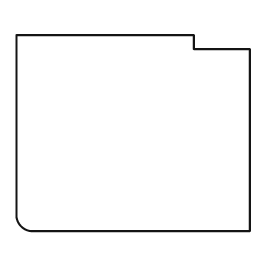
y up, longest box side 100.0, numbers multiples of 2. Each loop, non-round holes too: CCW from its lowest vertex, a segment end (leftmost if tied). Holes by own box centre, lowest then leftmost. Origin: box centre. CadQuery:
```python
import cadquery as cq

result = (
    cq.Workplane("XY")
    .moveTo(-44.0, -42.0)
    .lineTo(50.0, -42.0)
    .lineTo(50.0, 36.0)
    .lineTo(26.0, 36.0)
    .lineTo(26.0, 42.0)
    .lineTo(-50.0, 42.0)
    .lineTo(-50.0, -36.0)
    .threePointArc((-48.0, -40.0), (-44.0, -42.0))
    .close()
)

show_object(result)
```